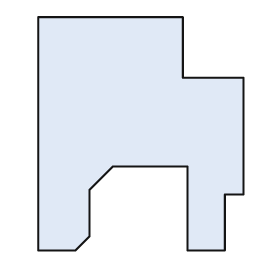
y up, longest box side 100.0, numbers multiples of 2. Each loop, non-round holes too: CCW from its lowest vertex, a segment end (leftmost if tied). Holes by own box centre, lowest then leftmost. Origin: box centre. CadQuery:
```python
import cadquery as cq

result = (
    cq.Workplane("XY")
    .moveTo(-44.0, -50.0)
    .lineTo(-28.0, -50.0)
    .lineTo(-22.0, -44.0)
    .lineTo(-22.0, -24.0)
    .lineTo(-12.0, -14.0)
    .lineTo(20.0, -14.0)
    .lineTo(20.0, -50.0)
    .lineTo(36.0, -50.0)
    .lineTo(36.0, -26.0)
    .lineTo(44.0, -26.0)
    .lineTo(44.0, 24.0)
    .lineTo(18.0, 24.0)
    .lineTo(18.0, 50.0)
    .lineTo(-44.0, 50.0)
    .close()
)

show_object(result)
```